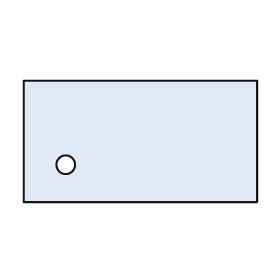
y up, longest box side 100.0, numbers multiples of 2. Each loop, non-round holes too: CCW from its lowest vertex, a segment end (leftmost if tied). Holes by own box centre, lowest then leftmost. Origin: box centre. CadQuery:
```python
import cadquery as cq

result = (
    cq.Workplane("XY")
    .moveTo(-50.0, -26.0)
    .lineTo(50.0, -26.0)
    .lineTo(50.0, 26.0)
    .lineTo(-50.0, 26.0)
    .close()
    .moveTo(-32.0, -10.0)
    .circle(4.0)
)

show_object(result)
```